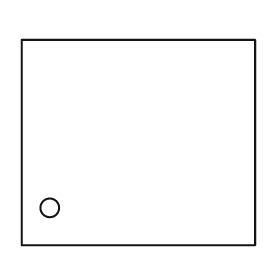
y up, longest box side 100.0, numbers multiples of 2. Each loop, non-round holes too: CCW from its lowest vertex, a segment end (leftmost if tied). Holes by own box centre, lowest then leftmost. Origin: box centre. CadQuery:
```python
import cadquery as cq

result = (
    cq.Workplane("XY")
    .moveTo(-50.0, -44.0)
    .lineTo(50.0, -44.0)
    .lineTo(50.0, 44.0)
    .lineTo(-50.0, 44.0)
    .close()
    .moveTo(-38.0, -28.0)
    .circle(4.0)
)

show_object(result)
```